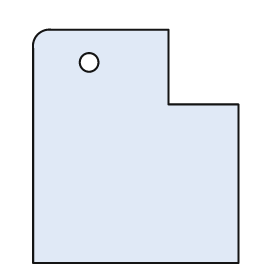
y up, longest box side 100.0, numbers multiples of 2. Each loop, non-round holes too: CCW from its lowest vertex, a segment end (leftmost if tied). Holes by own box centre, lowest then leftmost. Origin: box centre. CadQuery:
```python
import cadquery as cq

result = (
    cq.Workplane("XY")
    .moveTo(-44.0, -50.0)
    .lineTo(44.0, -50.0)
    .lineTo(44.0, 18.0)
    .lineTo(14.0, 18.0)
    .lineTo(14.0, 50.0)
    .lineTo(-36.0, 50.0)
    .threePointArc((-42.0, 48.0), (-44.0, 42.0))
    .close()
    .moveTo(-20.0, 36.0)
    .circle(4.0)
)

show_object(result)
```